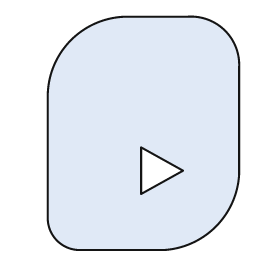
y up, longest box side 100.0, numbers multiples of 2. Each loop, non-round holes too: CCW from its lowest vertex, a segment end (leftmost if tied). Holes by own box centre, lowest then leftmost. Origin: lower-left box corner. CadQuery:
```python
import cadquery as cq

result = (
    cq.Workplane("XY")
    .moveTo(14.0, 0.0)
    .lineTo(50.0, 0.0)
    .threePointArc((72.0, 10.0), (82.0, 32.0))
    .lineTo(82.0, 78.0)
    .threePointArc((76.0, 94.0), (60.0, 100.0))
    .lineTo(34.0, 100.0)
    .threePointArc((10.0, 90.0), (0.0, 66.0))
    .lineTo(0.0, 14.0)
    .threePointArc((4.0, 4.0), (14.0, 0.0))
    .close()
    .moveTo(40.0, 24.0)
    .lineTo(58.0, 34.0)
    .lineTo(40.0, 44.0)
    .close()
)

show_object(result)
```